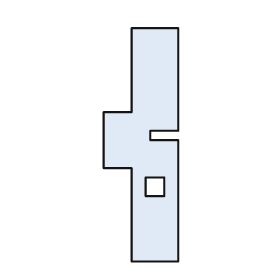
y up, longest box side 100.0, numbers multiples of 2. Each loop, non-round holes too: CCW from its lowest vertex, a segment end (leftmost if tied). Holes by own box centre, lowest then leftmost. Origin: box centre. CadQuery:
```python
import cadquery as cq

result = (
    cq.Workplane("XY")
    .moveTo(-4.0, -50.0)
    .lineTo(16.0, -50.0)
    .lineTo(16.0, 2.0)
    .lineTo(4.0, 2.0)
    .lineTo(4.0, 6.0)
    .lineTo(16.0, 6.0)
    .lineTo(16.0, 50.0)
    .lineTo(-4.0, 50.0)
    .lineTo(-4.0, 14.0)
    .lineTo(-16.0, 14.0)
    .lineTo(-16.0, -10.0)
    .lineTo(-4.0, -10.0)
    .close()
    .moveTo(2.0, -22.0)
    .lineTo(10.0, -22.0)
    .lineTo(10.0, -14.0)
    .lineTo(2.0, -14.0)
    .close()
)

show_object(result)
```